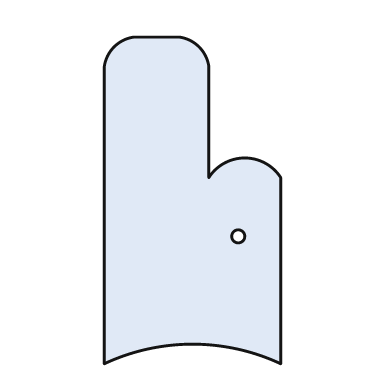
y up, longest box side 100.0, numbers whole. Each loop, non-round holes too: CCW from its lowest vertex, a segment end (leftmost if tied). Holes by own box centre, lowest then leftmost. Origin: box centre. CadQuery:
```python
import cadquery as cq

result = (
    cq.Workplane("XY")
    .moveTo(-27.0, -50.0)
    .threePointArc((0.0, -44.0), (27.0, -50.0))
    .lineTo(27.0, 7.0)
    .threePointArc((16.0, 13.0), (5.0, 7.0))
    .lineTo(5.0, 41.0)
    .threePointArc((2.0, 47.0), (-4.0, 50.0))
    .lineTo(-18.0, 50.0)
    .threePointArc((-24.0, 47.0), (-27.0, 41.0))
    .close()
    .moveTo(14.0, -11.0)
    .circle(2.0)
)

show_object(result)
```